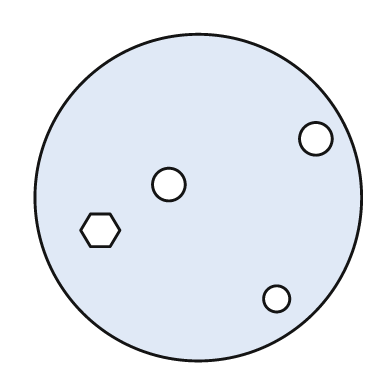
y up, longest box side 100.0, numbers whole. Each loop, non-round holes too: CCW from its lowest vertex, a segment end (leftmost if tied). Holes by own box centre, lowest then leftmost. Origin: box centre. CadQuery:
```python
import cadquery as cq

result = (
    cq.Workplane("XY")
    .moveTo(0.0, 0.0)
    .circle(50.0)
    .moveTo(24.0, -31.0)
    .circle(4.0)
    .moveTo(-33.0, -15.0)
    .lineTo(-27.0, -15.0)
    .lineTo(-24.0, -10.0)
    .lineTo(-27.0, -5.0)
    .lineTo(-33.0, -5.0)
    .lineTo(-36.0, -10.0)
    .close()
    .moveTo(-9.0, 4.0)
    .circle(5.0)
    .moveTo(36.0, 18.0)
    .circle(5.0)
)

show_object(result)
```